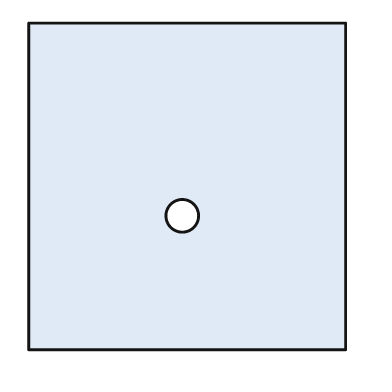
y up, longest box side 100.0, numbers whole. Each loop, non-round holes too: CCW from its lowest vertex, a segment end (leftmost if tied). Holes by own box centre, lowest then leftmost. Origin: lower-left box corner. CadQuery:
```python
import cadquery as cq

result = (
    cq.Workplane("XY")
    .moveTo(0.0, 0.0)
    .lineTo(97.0, 0.0)
    .lineTo(97.0, 100.0)
    .lineTo(0.0, 100.0)
    .close()
    .moveTo(47.0, 41.0)
    .circle(5.0)
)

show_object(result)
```